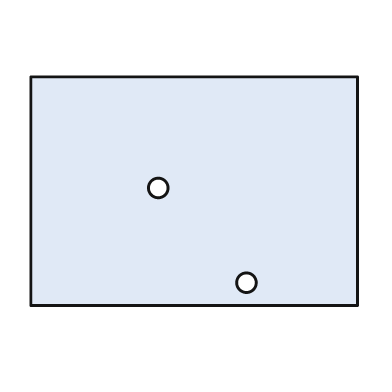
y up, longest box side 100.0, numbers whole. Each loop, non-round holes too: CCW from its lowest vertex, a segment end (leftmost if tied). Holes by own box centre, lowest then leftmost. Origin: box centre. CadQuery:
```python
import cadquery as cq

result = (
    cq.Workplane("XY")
    .moveTo(-50.0, -35.0)
    .lineTo(50.0, -35.0)
    .lineTo(50.0, 35.0)
    .lineTo(-50.0, 35.0)
    .close()
    .moveTo(16.0, -28.0)
    .circle(3.0)
    .moveTo(-11.0, 1.0)
    .circle(3.0)
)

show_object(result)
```